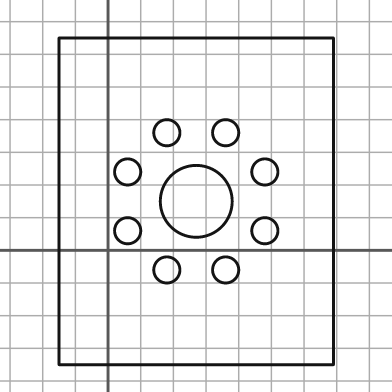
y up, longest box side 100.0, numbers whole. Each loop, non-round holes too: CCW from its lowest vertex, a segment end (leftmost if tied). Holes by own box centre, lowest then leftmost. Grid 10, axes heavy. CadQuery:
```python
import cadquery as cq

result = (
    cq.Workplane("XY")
    .moveTo(-15.0, -35.0)
    .lineTo(69.0, -35.0)
    .lineTo(69.0, 65.0)
    .lineTo(-15.0, 65.0)
    .close()
    .moveTo(18.0, -6.0)
    .circle(4.0)
    .moveTo(36.0, -6.0)
    .circle(4.0)
    .moveTo(6.0, 6.0)
    .circle(4.0)
    .moveTo(48.0, 6.0)
    .circle(4.0)
    .moveTo(27.0, 15.0)
    .circle(11.0)
    .moveTo(6.0, 24.0)
    .circle(4.0)
    .moveTo(48.0, 24.0)
    .circle(4.0)
    .moveTo(18.0, 36.0)
    .circle(4.0)
    .moveTo(36.0, 36.0)
    .circle(4.0)
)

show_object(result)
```